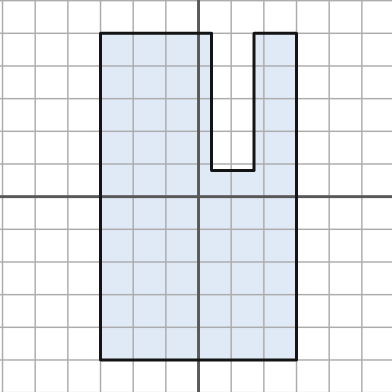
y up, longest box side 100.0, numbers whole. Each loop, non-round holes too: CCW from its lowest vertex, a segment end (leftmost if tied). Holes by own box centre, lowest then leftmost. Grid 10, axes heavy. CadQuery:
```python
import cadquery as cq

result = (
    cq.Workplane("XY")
    .moveTo(-30.0, -50.0)
    .lineTo(30.0, -50.0)
    .lineTo(30.0, 50.0)
    .lineTo(17.0, 50.0)
    .lineTo(17.0, 8.0)
    .lineTo(4.0, 8.0)
    .lineTo(4.0, 50.0)
    .lineTo(-30.0, 50.0)
    .close()
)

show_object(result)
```